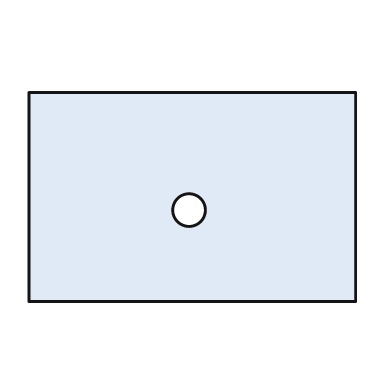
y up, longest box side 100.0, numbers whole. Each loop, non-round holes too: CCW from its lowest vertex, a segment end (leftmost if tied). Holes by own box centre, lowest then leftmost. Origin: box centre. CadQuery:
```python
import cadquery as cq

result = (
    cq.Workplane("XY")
    .moveTo(-50.0, -32.0)
    .lineTo(50.0, -32.0)
    .lineTo(50.0, 32.0)
    .lineTo(-50.0, 32.0)
    .close()
    .moveTo(-1.0, -4.0)
    .circle(5.0)
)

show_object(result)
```